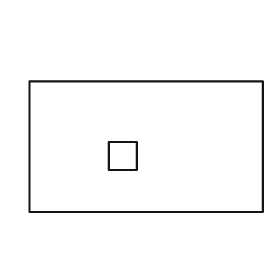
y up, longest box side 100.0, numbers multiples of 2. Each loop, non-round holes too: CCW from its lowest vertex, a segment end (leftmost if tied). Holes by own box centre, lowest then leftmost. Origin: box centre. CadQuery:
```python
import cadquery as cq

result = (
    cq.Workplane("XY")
    .moveTo(-50.0, -28.0)
    .lineTo(50.0, -28.0)
    .lineTo(50.0, 28.0)
    .lineTo(-50.0, 28.0)
    .close()
    .moveTo(-16.0, -10.0)
    .lineTo(-4.0, -10.0)
    .lineTo(-4.0, 2.0)
    .lineTo(-16.0, 2.0)
    .close()
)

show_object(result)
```